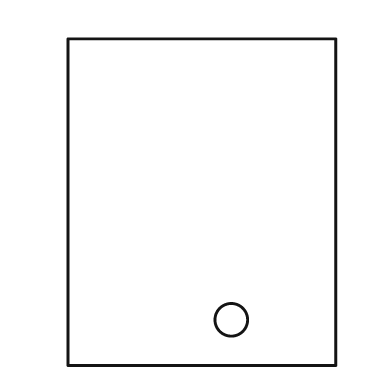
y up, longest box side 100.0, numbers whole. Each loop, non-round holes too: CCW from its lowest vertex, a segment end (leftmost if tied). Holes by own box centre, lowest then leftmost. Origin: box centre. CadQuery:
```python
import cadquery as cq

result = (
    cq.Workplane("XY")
    .moveTo(-41.0, -50.0)
    .lineTo(41.0, -50.0)
    .lineTo(41.0, 50.0)
    .lineTo(-41.0, 50.0)
    .close()
    .moveTo(9.0, -36.0)
    .circle(5.0)
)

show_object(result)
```